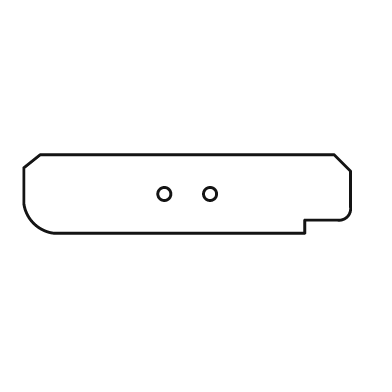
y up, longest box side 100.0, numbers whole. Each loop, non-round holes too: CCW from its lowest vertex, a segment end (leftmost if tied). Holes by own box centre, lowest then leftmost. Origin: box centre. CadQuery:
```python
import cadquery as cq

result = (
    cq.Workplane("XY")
    .moveTo(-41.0, -12.0)
    .lineTo(36.0, -12.0)
    .lineTo(36.0, -8.0)
    .lineTo(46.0, -8.0)
    .threePointArc((49.0, -7.0), (50.0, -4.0))
    .lineTo(50.0, 7.0)
    .lineTo(45.0, 12.0)
    .lineTo(-45.0, 12.0)
    .lineTo(-50.0, 8.0)
    .lineTo(-50.0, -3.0)
    .threePointArc((-47.0, -9.0), (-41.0, -12.0))
    .close()
    .moveTo(-7.0, 0.0)
    .circle(2.0)
    .moveTo(7.0, 0.0)
    .circle(2.0)
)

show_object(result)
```